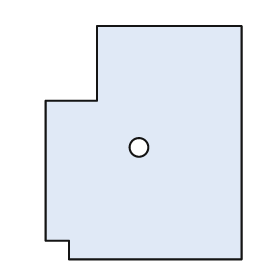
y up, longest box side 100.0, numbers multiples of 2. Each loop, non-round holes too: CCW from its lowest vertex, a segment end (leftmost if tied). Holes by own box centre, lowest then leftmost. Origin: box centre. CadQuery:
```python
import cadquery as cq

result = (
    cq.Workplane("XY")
    .moveTo(-32.0, -50.0)
    .lineTo(42.0, -50.0)
    .lineTo(42.0, 50.0)
    .lineTo(-20.0, 50.0)
    .lineTo(-20.0, 18.0)
    .lineTo(-42.0, 18.0)
    .lineTo(-42.0, -42.0)
    .lineTo(-32.0, -42.0)
    .close()
    .moveTo(-2.0, -2.0)
    .circle(4.0)
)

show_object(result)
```